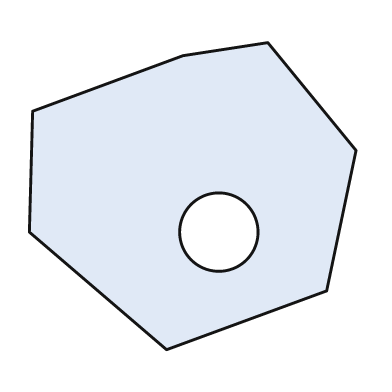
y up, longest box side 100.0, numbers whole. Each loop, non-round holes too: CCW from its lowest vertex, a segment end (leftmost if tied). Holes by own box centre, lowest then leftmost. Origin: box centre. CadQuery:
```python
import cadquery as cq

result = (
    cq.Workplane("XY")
    .moveTo(-8.0, -47.0)
    .lineTo(41.0, -29.0)
    .lineTo(50.0, 14.0)
    .lineTo(23.0, 47.0)
    .lineTo(-3.0, 43.0)
    .lineTo(-49.0, 26.0)
    .lineTo(-50.0, -11.0)
    .close()
    .moveTo(8.0, -11.0)
    .circle(12.0)
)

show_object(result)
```